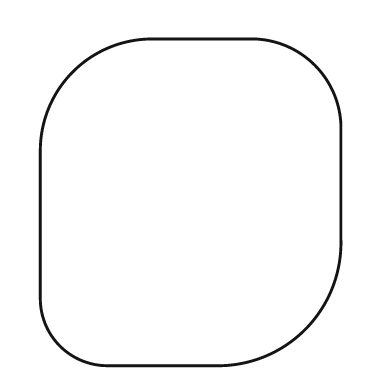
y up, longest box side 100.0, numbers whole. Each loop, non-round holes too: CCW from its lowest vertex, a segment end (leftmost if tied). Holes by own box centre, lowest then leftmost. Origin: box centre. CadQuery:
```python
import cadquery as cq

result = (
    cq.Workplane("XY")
    .moveTo(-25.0, -50.0)
    .lineTo(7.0, -50.0)
    .threePointArc((35.0, -39.0), (46.0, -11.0))
    .lineTo(46.0, 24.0)
    .threePointArc((38.0, 42.0), (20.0, 50.0))
    .lineTo(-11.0, 50.0)
    .threePointArc((-36.0, 40.0), (-46.0, 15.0))
    .lineTo(-46.0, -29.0)
    .threePointArc((-40.0, -44.0), (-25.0, -50.0))
    .close()
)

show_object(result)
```